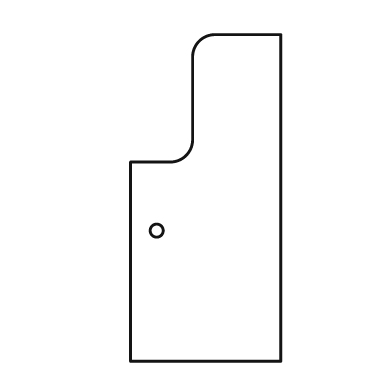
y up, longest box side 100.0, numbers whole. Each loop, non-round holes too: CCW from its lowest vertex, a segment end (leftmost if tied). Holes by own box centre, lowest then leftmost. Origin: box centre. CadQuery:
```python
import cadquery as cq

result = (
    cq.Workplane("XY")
    .moveTo(-23.0, -50.0)
    .lineTo(23.0, -50.0)
    .lineTo(23.0, 50.0)
    .lineTo(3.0, 50.0)
    .threePointArc((-2.0, 48.0), (-4.0, 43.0))
    .lineTo(-4.0, 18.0)
    .threePointArc((-6.0, 13.0), (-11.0, 11.0))
    .lineTo(-23.0, 11.0)
    .close()
    .moveTo(-15.0, -10.0)
    .circle(2.0)
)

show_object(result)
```